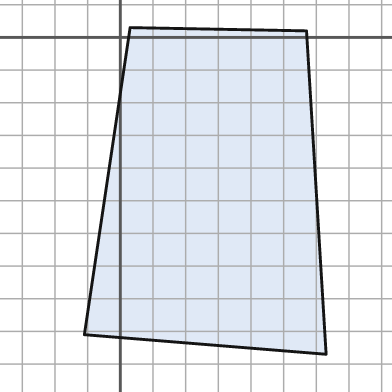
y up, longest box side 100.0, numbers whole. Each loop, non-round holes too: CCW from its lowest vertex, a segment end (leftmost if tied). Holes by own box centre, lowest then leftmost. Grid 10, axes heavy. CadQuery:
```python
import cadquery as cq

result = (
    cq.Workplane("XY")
    .moveTo(63.0, -97.0)
    .lineTo(57.0, 2.0)
    .lineTo(3.0, 3.0)
    .lineTo(-11.0, -91.0)
    .close()
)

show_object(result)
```